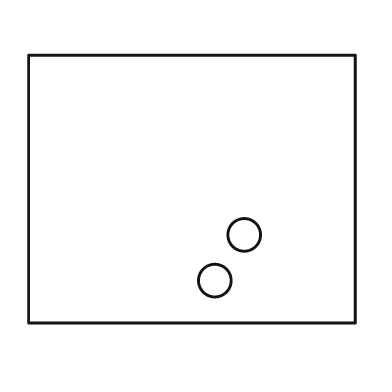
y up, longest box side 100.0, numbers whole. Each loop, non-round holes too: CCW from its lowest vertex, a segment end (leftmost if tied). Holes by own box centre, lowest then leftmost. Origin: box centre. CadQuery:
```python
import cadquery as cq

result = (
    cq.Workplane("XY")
    .moveTo(-50.0, -41.0)
    .lineTo(50.0, -41.0)
    .lineTo(50.0, 41.0)
    .lineTo(-50.0, 41.0)
    .close()
    .moveTo(7.0, -28.0)
    .circle(5.0)
    .moveTo(16.0, -14.0)
    .circle(5.0)
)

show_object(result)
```